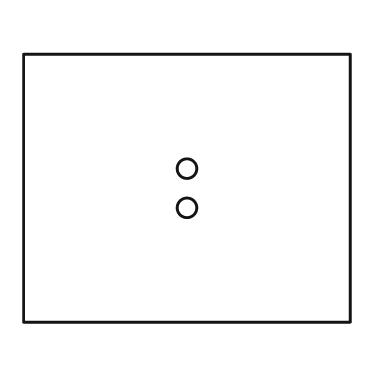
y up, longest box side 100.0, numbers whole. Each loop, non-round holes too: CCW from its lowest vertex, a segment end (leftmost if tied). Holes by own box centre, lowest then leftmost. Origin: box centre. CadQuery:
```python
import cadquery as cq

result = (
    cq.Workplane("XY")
    .moveTo(-50.0, -41.0)
    .lineTo(50.0, -41.0)
    .lineTo(50.0, 41.0)
    .lineTo(-50.0, 41.0)
    .close()
    .moveTo(0.0, -6.0)
    .circle(3.0)
    .moveTo(0.0, 6.0)
    .circle(3.0)
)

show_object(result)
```